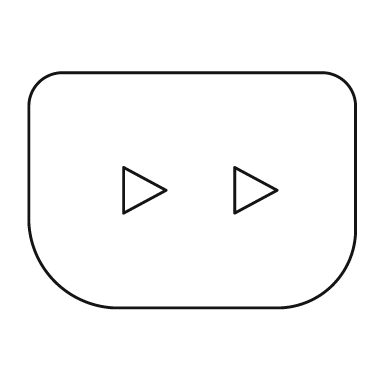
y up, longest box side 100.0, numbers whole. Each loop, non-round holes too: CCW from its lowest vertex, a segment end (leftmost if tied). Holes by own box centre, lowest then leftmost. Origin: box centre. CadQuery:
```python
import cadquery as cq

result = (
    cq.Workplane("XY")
    .moveTo(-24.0, -36.0)
    .lineTo(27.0, -36.0)
    .threePointArc((43.0, -29.0), (50.0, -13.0))
    .lineTo(50.0, 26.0)
    .threePointArc((47.0, 33.0), (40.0, 36.0))
    .lineTo(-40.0, 36.0)
    .threePointArc((-47.0, 33.0), (-50.0, 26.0))
    .lineTo(-50.0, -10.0)
    .threePointArc((-42.0, -28.0), (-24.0, -36.0))
    .close()
    .moveTo(-21.0, -7.0)
    .lineTo(-8.0, 0.0)
    .lineTo(-21.0, 7.0)
    .close()
    .moveTo(13.0, -7.0)
    .lineTo(26.0, 0.0)
    .lineTo(13.0, 7.0)
    .close()
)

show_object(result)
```